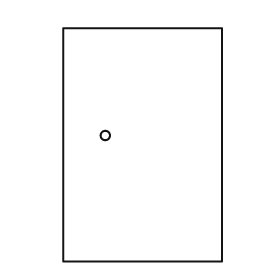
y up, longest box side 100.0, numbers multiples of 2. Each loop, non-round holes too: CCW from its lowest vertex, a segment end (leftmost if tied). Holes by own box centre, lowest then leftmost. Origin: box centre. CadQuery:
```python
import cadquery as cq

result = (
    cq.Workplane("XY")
    .moveTo(-34.0, -50.0)
    .lineTo(34.0, -50.0)
    .lineTo(34.0, 50.0)
    .lineTo(-34.0, 50.0)
    .close()
    .moveTo(-16.0, 4.0)
    .circle(2.0)
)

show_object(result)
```